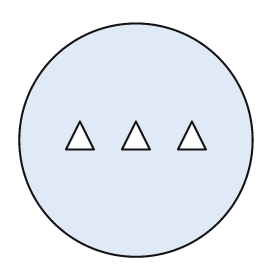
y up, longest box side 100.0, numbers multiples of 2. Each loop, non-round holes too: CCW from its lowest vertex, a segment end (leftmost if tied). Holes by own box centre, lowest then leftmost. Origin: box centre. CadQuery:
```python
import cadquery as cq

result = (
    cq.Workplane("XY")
    .moveTo(0.0, 0.0)
    .circle(50.0)
    .moveTo(-30.0, -4.0)
    .lineTo(-18.0, -4.0)
    .lineTo(-24.0, 8.0)
    .close()
    .moveTo(-6.0, -4.0)
    .lineTo(6.0, -4.0)
    .lineTo(0.0, 8.0)
    .close()
    .moveTo(18.0, -4.0)
    .lineTo(30.0, -4.0)
    .lineTo(24.0, 8.0)
    .close()
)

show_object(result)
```